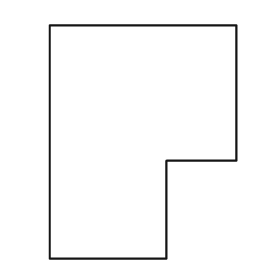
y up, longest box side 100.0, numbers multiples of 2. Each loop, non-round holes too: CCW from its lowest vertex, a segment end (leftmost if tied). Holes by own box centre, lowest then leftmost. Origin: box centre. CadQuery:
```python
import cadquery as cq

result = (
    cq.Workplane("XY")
    .moveTo(-40.0, -50.0)
    .lineTo(10.0, -50.0)
    .lineTo(10.0, -8.0)
    .lineTo(40.0, -8.0)
    .lineTo(40.0, 50.0)
    .lineTo(-40.0, 50.0)
    .close()
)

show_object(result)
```